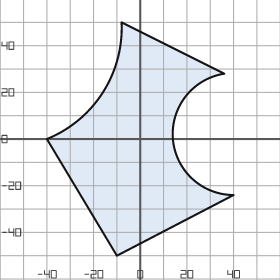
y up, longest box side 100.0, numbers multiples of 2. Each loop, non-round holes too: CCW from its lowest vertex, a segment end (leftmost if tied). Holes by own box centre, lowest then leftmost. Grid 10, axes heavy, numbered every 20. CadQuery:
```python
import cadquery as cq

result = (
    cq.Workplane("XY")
    .moveTo(-10.0, -50.0)
    .lineTo(40.0, -24.0)
    .threePointArc((14.0, 0.0), (36.0, 28.0))
    .lineTo(-8.0, 50.0)
    .threePointArc((-16.0, 20.0), (-40.0, 0.0))
    .close()
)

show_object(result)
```